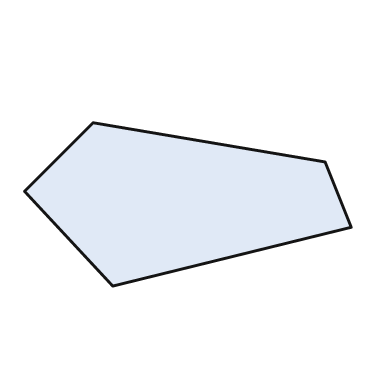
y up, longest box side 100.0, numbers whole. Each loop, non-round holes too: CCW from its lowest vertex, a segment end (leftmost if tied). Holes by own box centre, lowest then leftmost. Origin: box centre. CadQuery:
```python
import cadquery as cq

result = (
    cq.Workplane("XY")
    .moveTo(-23.0, -25.0)
    .lineTo(50.0, -7.0)
    .lineTo(42.0, 13.0)
    .lineTo(-29.0, 25.0)
    .lineTo(-50.0, 4.0)
    .close()
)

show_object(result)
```